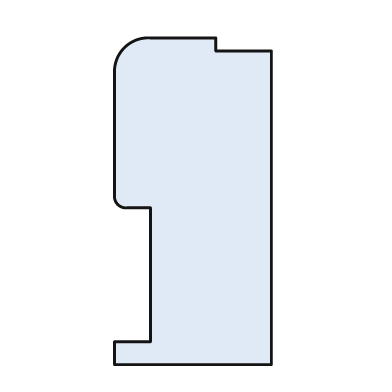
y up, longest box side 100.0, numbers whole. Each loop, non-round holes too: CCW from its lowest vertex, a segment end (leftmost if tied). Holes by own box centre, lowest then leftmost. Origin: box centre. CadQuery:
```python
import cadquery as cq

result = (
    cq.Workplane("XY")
    .moveTo(-24.0, -50.0)
    .lineTo(24.0, -50.0)
    .lineTo(24.0, 46.0)
    .lineTo(7.0, 46.0)
    .lineTo(7.0, 50.0)
    .lineTo(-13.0, 50.0)
    .threePointArc((-21.0, 47.0), (-24.0, 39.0))
    .lineTo(-24.0, 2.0)
    .threePointArc((-23.0, -1.0), (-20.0, -2.0))
    .lineTo(-13.0, -2.0)
    .lineTo(-13.0, -43.0)
    .lineTo(-24.0, -43.0)
    .close()
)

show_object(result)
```